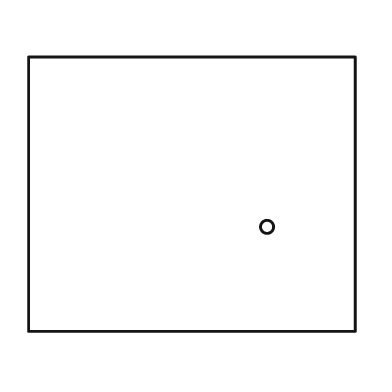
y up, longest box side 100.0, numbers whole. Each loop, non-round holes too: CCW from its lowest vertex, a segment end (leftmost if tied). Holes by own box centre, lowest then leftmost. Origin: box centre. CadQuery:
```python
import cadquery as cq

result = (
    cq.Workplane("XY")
    .moveTo(-50.0, -42.0)
    .lineTo(50.0, -42.0)
    .lineTo(50.0, 42.0)
    .lineTo(-50.0, 42.0)
    .close()
    .moveTo(23.0, -10.0)
    .circle(2.0)
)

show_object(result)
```